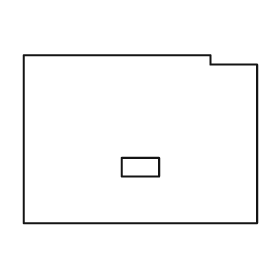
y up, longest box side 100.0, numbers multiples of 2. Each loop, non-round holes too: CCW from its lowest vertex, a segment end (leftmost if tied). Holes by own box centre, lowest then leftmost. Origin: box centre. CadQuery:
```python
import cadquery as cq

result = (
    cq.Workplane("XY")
    .moveTo(-50.0, -36.0)
    .lineTo(50.0, -36.0)
    .lineTo(50.0, 32.0)
    .lineTo(30.0, 32.0)
    .lineTo(30.0, 36.0)
    .lineTo(-50.0, 36.0)
    .close()
    .moveTo(-8.0, -16.0)
    .lineTo(8.0, -16.0)
    .lineTo(8.0, -8.0)
    .lineTo(-8.0, -8.0)
    .close()
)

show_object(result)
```